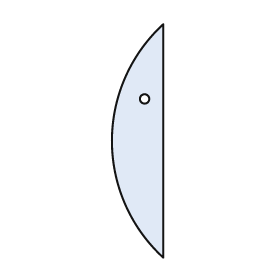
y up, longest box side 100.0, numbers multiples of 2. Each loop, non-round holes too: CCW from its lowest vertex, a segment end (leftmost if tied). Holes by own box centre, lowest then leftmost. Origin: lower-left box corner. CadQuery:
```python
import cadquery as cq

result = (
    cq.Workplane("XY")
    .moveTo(22.0, 0.0)
    .lineTo(22.0, 100.0)
    .threePointArc((0.0, 50.0), (22.0, 0.0))
    .close()
    .moveTo(14.0, 68.0)
    .circle(2.0)
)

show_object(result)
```